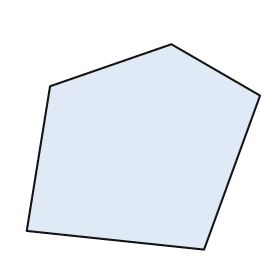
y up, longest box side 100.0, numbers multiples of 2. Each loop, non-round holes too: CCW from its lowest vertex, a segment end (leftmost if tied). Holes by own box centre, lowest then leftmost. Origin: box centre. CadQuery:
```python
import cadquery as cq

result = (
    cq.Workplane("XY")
    .moveTo(26.0, -44.0)
    .lineTo(50.0, 22.0)
    .lineTo(12.0, 44.0)
    .lineTo(-40.0, 26.0)
    .lineTo(-50.0, -36.0)
    .close()
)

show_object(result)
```